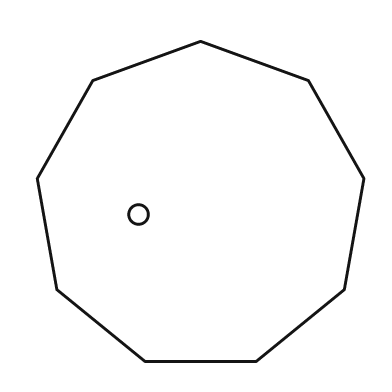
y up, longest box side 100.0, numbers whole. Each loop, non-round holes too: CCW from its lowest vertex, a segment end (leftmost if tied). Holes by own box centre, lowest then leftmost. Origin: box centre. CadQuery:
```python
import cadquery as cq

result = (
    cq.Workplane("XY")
    .moveTo(-17.0, -49.0)
    .lineTo(17.0, -49.0)
    .lineTo(44.0, -27.0)
    .lineTo(50.0, 7.0)
    .lineTo(33.0, 37.0)
    .lineTo(0.0, 49.0)
    .lineTo(-33.0, 37.0)
    .lineTo(-50.0, 7.0)
    .lineTo(-44.0, -27.0)
    .close()
    .moveTo(-19.0, -4.0)
    .circle(3.0)
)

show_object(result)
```